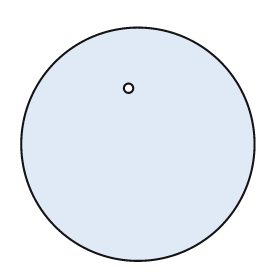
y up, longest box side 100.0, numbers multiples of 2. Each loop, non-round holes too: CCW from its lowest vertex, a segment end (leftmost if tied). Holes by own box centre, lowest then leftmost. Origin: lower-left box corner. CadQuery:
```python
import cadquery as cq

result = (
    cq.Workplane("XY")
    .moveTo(50.0, 50.0)
    .circle(50.0)
    .moveTo(46.0, 74.0)
    .circle(2.0)
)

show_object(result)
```